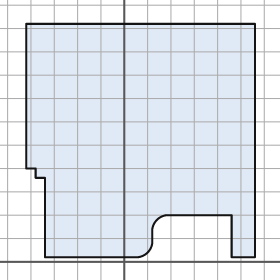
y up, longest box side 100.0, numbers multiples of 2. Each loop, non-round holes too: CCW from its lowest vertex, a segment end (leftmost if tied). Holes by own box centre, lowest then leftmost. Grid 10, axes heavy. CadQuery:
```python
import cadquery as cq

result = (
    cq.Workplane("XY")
    .moveTo(-34.0, 2.0)
    .lineTo(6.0, 2.0)
    .threePointArc((10.0, 4.0), (12.0, 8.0))
    .lineTo(12.0, 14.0)
    .threePointArc((14.0, 18.0), (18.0, 20.0))
    .lineTo(46.0, 20.0)
    .lineTo(46.0, 2.0)
    .lineTo(56.0, 2.0)
    .lineTo(56.0, 102.0)
    .lineTo(-42.0, 102.0)
    .lineTo(-42.0, 40.0)
    .lineTo(-38.0, 40.0)
    .lineTo(-38.0, 36.0)
    .lineTo(-34.0, 36.0)
    .close()
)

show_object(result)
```